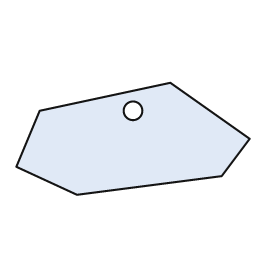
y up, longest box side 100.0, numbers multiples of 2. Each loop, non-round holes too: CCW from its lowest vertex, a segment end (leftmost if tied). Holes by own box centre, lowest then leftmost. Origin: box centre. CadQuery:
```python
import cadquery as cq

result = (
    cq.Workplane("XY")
    .moveTo(-24.0, -24.0)
    .lineTo(38.0, -16.0)
    .lineTo(50.0, 0.0)
    .lineTo(16.0, 24.0)
    .lineTo(-40.0, 12.0)
    .lineTo(-50.0, -12.0)
    .close()
    .moveTo(0.0, 12.0)
    .circle(4.0)
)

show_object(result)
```